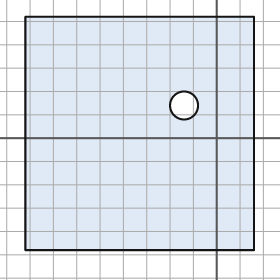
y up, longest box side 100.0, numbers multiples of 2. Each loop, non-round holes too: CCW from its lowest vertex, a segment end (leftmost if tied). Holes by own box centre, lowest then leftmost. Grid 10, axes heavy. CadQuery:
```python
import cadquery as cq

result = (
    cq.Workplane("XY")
    .moveTo(-82.0, -48.0)
    .lineTo(16.0, -48.0)
    .lineTo(16.0, 52.0)
    .lineTo(-82.0, 52.0)
    .close()
    .moveTo(-14.0, 14.0)
    .circle(6.0)
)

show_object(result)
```